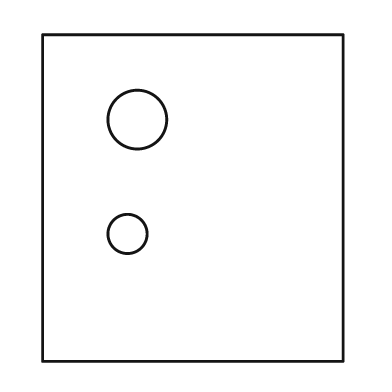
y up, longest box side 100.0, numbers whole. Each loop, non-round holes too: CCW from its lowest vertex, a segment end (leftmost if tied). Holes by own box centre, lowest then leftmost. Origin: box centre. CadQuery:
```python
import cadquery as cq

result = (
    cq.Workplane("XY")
    .moveTo(-46.0, -50.0)
    .lineTo(46.0, -50.0)
    .lineTo(46.0, 50.0)
    .lineTo(-46.0, 50.0)
    .close()
    .moveTo(-20.0, -11.0)
    .circle(6.0)
    .moveTo(-17.0, 24.0)
    .circle(9.0)
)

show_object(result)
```